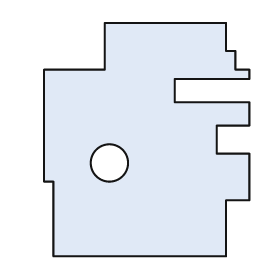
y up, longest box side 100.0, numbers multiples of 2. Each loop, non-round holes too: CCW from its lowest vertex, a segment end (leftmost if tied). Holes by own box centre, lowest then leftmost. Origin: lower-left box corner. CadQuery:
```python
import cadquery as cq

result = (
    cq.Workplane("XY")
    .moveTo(4.0, 0.0)
    .lineTo(78.0, 0.0)
    .lineTo(78.0, 24.0)
    .lineTo(88.0, 24.0)
    .lineTo(88.0, 44.0)
    .lineTo(74.0, 44.0)
    .lineTo(74.0, 56.0)
    .lineTo(88.0, 56.0)
    .lineTo(88.0, 66.0)
    .lineTo(56.0, 66.0)
    .lineTo(56.0, 76.0)
    .lineTo(88.0, 76.0)
    .lineTo(88.0, 80.0)
    .lineTo(82.0, 80.0)
    .lineTo(82.0, 88.0)
    .lineTo(78.0, 88.0)
    .lineTo(78.0, 100.0)
    .lineTo(26.0, 100.0)
    .lineTo(26.0, 80.0)
    .lineTo(0.0, 80.0)
    .lineTo(0.0, 32.0)
    .lineTo(4.0, 32.0)
    .close()
    .moveTo(28.0, 40.0)
    .circle(8.0)
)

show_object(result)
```